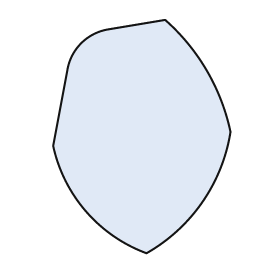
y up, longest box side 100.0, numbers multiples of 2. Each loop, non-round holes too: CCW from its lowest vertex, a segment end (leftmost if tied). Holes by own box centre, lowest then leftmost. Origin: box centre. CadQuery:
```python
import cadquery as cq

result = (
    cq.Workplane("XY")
    .moveTo(2.0, -50.0)
    .threePointArc((26.0, -28.0), (38.0, 2.0))
    .threePointArc((28.0, 28.0), (10.0, 50.0))
    .lineTo(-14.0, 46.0)
    .threePointArc((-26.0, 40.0), (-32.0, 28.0))
    .lineTo(-38.0, -4.0)
    .threePointArc((-24.0, -32.0), (2.0, -50.0))
    .close()
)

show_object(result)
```